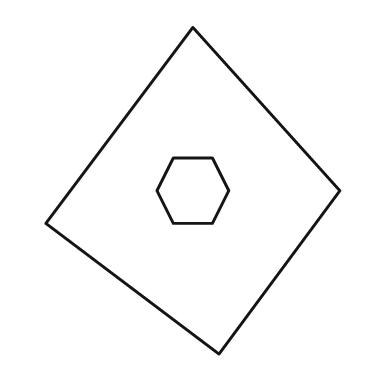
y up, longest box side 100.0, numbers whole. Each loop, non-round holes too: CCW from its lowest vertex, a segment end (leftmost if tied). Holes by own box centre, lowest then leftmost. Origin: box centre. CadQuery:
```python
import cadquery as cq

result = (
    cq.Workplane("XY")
    .moveTo(8.0, -50.0)
    .lineTo(45.0, 0.0)
    .lineTo(0.0, 50.0)
    .lineTo(-45.0, -10.0)
    .close()
    .moveTo(-6.0, -10.0)
    .lineTo(6.0, -10.0)
    .lineTo(11.0, 0.0)
    .lineTo(6.0, 10.0)
    .lineTo(-6.0, 10.0)
    .lineTo(-11.0, 0.0)
    .close()
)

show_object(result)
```